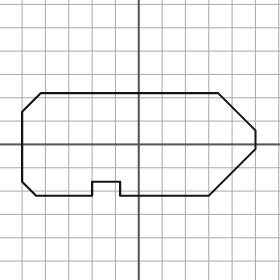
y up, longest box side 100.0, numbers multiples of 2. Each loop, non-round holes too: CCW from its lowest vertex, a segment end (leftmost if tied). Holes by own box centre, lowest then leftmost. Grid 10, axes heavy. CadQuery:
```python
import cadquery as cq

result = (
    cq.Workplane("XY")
    .moveTo(-44.0, -22.0)
    .lineTo(-20.0, -22.0)
    .lineTo(-20.0, -16.0)
    .lineTo(-8.0, -16.0)
    .lineTo(-8.0, -22.0)
    .lineTo(30.0, -22.0)
    .lineTo(50.0, -2.0)
    .lineTo(50.0, 6.0)
    .lineTo(34.0, 22.0)
    .lineTo(-42.0, 22.0)
    .lineTo(-50.0, 14.0)
    .lineTo(-50.0, -16.0)
    .close()
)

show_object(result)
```